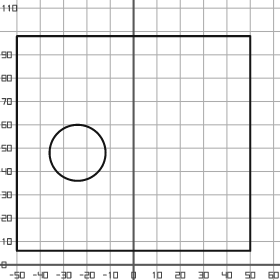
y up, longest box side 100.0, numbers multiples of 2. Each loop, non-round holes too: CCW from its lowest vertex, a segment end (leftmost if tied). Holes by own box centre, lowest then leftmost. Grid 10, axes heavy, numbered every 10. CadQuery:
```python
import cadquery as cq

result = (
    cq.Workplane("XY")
    .moveTo(-50.0, 6.0)
    .lineTo(50.0, 6.0)
    .lineTo(50.0, 98.0)
    .lineTo(-50.0, 98.0)
    .close()
    .moveTo(-24.0, 48.0)
    .circle(12.0)
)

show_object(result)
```